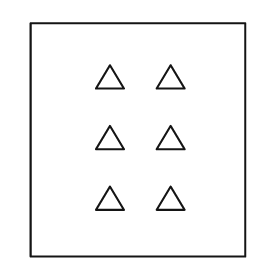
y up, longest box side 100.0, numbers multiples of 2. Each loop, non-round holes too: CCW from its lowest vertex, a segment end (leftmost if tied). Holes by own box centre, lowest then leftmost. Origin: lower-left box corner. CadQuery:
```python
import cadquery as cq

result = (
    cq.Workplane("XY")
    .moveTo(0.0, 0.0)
    .lineTo(92.0, 0.0)
    .lineTo(92.0, 100.0)
    .lineTo(0.0, 100.0)
    .close()
    .moveTo(28.0, 20.0)
    .lineTo(40.0, 20.0)
    .lineTo(34.0, 30.0)
    .close()
    .moveTo(54.0, 20.0)
    .lineTo(66.0, 20.0)
    .lineTo(60.0, 30.0)
    .close()
    .moveTo(28.0, 46.0)
    .lineTo(40.0, 46.0)
    .lineTo(34.0, 56.0)
    .close()
    .moveTo(54.0, 46.0)
    .lineTo(66.0, 46.0)
    .lineTo(60.0, 56.0)
    .close()
    .moveTo(28.0, 72.0)
    .lineTo(40.0, 72.0)
    .lineTo(34.0, 82.0)
    .close()
    .moveTo(54.0, 72.0)
    .lineTo(66.0, 72.0)
    .lineTo(60.0, 82.0)
    .close()
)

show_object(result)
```